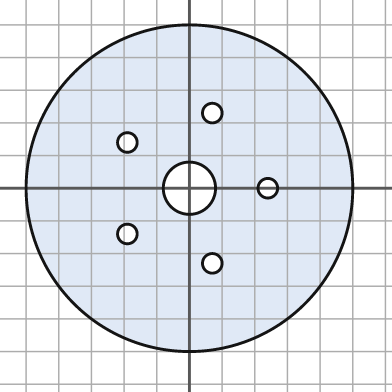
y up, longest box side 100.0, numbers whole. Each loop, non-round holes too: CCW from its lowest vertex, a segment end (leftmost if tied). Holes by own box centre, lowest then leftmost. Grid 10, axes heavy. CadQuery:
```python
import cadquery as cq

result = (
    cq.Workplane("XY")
    .moveTo(0.0, 0.0)
    .circle(50.0)
    .moveTo(7.0, -23.0)
    .circle(3.0)
    .moveTo(-19.0, -14.0)
    .circle(3.0)
    .moveTo(0.0, 0.0)
    .circle(8.0)
    .moveTo(24.0, 0.0)
    .circle(3.0)
    .moveTo(-19.0, 14.0)
    .circle(3.0)
    .moveTo(7.0, 23.0)
    .circle(3.0)
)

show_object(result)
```